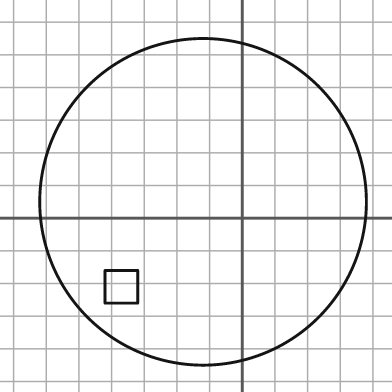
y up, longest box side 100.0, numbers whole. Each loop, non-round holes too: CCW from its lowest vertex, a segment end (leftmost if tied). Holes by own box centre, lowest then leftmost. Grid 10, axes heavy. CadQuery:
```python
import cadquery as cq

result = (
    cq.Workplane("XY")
    .moveTo(-12.0, 5.0)
    .circle(50.0)
    .moveTo(-42.0, -26.0)
    .lineTo(-32.0, -26.0)
    .lineTo(-32.0, -16.0)
    .lineTo(-42.0, -16.0)
    .close()
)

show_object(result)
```